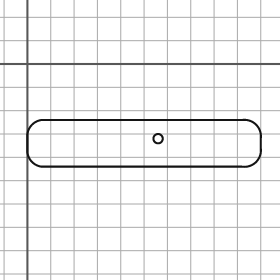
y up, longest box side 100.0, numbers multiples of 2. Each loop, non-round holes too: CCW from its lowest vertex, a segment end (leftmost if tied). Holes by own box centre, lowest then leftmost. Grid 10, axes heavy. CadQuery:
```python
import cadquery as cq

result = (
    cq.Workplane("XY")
    .moveTo(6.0, -44.0)
    .lineTo(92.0, -44.0)
    .threePointArc((98.0, -42.0), (100.0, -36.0))
    .lineTo(100.0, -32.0)
    .threePointArc((98.0, -26.0), (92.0, -24.0))
    .lineTo(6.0, -24.0)
    .threePointArc((2.0, -26.0), (0.0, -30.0))
    .lineTo(0.0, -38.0)
    .threePointArc((2.0, -42.0), (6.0, -44.0))
    .close()
    .moveTo(56.0, -32.0)
    .circle(2.0)
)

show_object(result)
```